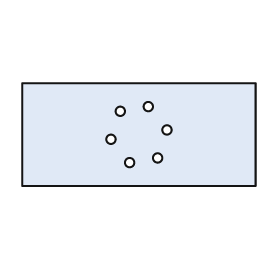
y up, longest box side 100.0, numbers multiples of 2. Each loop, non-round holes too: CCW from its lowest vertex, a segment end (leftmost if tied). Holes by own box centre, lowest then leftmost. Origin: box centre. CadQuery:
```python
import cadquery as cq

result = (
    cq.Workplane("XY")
    .moveTo(-50.0, -22.0)
    .lineTo(50.0, -22.0)
    .lineTo(50.0, 22.0)
    .lineTo(-50.0, 22.0)
    .close()
    .moveTo(-4.0, -12.0)
    .circle(2.0)
    .moveTo(8.0, -10.0)
    .circle(2.0)
    .moveTo(-12.0, -2.0)
    .circle(2.0)
    .moveTo(12.0, 2.0)
    .circle(2.0)
    .moveTo(-8.0, 10.0)
    .circle(2.0)
    .moveTo(4.0, 12.0)
    .circle(2.0)
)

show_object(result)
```